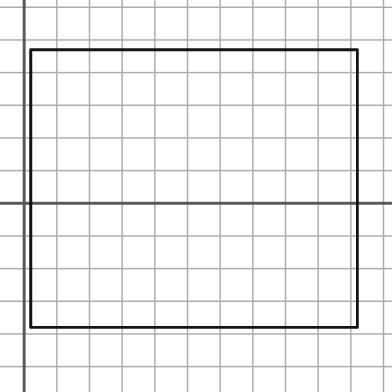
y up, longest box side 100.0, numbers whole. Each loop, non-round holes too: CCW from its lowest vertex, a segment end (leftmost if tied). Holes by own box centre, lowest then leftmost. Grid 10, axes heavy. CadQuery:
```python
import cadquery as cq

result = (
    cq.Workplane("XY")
    .moveTo(2.0, -38.0)
    .lineTo(102.0, -38.0)
    .lineTo(102.0, 47.0)
    .lineTo(2.0, 47.0)
    .close()
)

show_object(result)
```